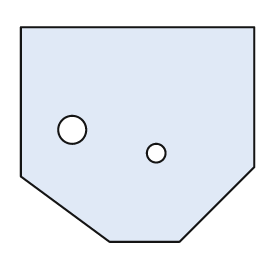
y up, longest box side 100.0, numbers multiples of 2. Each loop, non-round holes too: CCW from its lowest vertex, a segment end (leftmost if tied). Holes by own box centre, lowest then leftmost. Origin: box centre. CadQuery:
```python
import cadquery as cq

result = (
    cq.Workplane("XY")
    .moveTo(-12.0, -46.0)
    .lineTo(18.0, -46.0)
    .lineTo(50.0, -14.0)
    .lineTo(50.0, 46.0)
    .lineTo(-50.0, 46.0)
    .lineTo(-50.0, -18.0)
    .close()
    .moveTo(8.0, -8.0)
    .circle(4.0)
    .moveTo(-28.0, 2.0)
    .circle(6.0)
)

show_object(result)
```